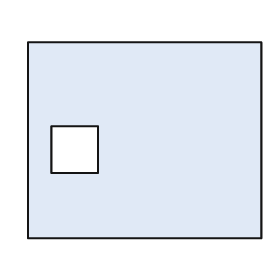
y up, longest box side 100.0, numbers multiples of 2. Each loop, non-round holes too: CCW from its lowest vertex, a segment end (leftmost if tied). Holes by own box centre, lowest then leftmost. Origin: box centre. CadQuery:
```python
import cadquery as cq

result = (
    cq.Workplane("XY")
    .moveTo(-50.0, -42.0)
    .lineTo(50.0, -42.0)
    .lineTo(50.0, 42.0)
    .lineTo(-50.0, 42.0)
    .close()
    .moveTo(-40.0, -14.0)
    .lineTo(-20.0, -14.0)
    .lineTo(-20.0, 6.0)
    .lineTo(-40.0, 6.0)
    .close()
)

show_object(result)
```